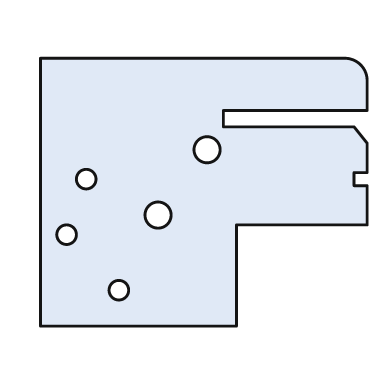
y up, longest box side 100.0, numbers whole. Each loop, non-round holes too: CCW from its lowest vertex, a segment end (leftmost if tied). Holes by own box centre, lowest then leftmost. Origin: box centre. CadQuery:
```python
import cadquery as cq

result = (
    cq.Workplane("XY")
    .moveTo(-50.0, -41.0)
    .lineTo(10.0, -41.0)
    .lineTo(10.0, -10.0)
    .lineTo(50.0, -10.0)
    .lineTo(50.0, 2.0)
    .lineTo(46.0, 2.0)
    .lineTo(46.0, 6.0)
    .lineTo(50.0, 6.0)
    .lineTo(50.0, 15.0)
    .lineTo(46.0, 20.0)
    .lineTo(6.0, 20.0)
    .lineTo(6.0, 25.0)
    .lineTo(50.0, 25.0)
    .lineTo(50.0, 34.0)
    .threePointArc((48.0, 39.0), (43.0, 41.0))
    .lineTo(-50.0, 41.0)
    .close()
    .moveTo(-26.0, -30.0)
    .circle(3.0)
    .moveTo(-42.0, -13.0)
    .circle(3.0)
    .moveTo(-14.0, -7.0)
    .circle(4.0)
    .moveTo(-36.0, 4.0)
    .circle(3.0)
    .moveTo(1.0, 13.0)
    .circle(4.0)
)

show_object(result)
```